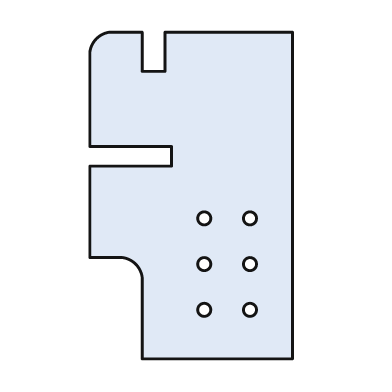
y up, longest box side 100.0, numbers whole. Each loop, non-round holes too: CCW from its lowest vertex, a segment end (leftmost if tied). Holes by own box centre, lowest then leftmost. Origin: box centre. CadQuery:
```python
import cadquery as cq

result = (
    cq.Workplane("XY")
    .moveTo(-15.0, -50.0)
    .lineTo(31.0, -50.0)
    .lineTo(31.0, 50.0)
    .lineTo(-8.0, 50.0)
    .lineTo(-8.0, 38.0)
    .lineTo(-15.0, 38.0)
    .lineTo(-15.0, 50.0)
    .lineTo(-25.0, 50.0)
    .threePointArc((-29.0, 48.0), (-31.0, 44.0))
    .lineTo(-31.0, 15.0)
    .lineTo(-6.0, 15.0)
    .lineTo(-6.0, 9.0)
    .lineTo(-31.0, 9.0)
    .lineTo(-31.0, -19.0)
    .lineTo(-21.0, -19.0)
    .threePointArc((-17.0, -21.0), (-15.0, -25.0))
    .close()
    .moveTo(4.0, -35.0)
    .circle(2.0)
    .moveTo(18.0, -35.0)
    .circle(2.0)
    .moveTo(4.0, -21.0)
    .circle(2.0)
    .moveTo(18.0, -21.0)
    .circle(2.0)
    .moveTo(4.0, -7.0)
    .circle(2.0)
    .moveTo(18.0, -7.0)
    .circle(2.0)
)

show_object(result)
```